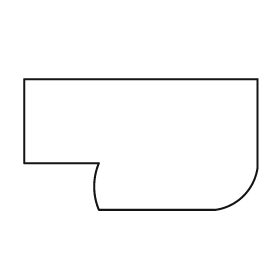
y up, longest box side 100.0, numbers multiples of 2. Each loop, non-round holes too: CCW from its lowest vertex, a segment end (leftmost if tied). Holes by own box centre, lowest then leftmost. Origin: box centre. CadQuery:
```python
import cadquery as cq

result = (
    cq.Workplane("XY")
    .moveTo(-18.0, -28.0)
    .lineTo(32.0, -28.0)
    .threePointArc((44.0, -22.0), (50.0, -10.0))
    .lineTo(50.0, 28.0)
    .lineTo(-50.0, 28.0)
    .lineTo(-50.0, -8.0)
    .lineTo(-18.0, -8.0)
    .threePointArc((-20.0, -18.0), (-18.0, -28.0))
    .close()
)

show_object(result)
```